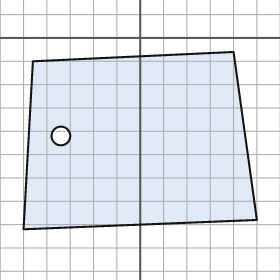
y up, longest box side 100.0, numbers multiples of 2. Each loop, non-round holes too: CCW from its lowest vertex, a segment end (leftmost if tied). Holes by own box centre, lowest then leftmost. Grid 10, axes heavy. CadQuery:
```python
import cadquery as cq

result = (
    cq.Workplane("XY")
    .moveTo(-50.0, -82.0)
    .lineTo(50.0, -78.0)
    .lineTo(40.0, -6.0)
    .lineTo(-46.0, -10.0)
    .close()
    .moveTo(-34.0, -42.0)
    .circle(4.0)
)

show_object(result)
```